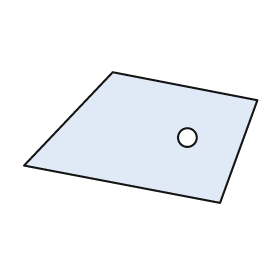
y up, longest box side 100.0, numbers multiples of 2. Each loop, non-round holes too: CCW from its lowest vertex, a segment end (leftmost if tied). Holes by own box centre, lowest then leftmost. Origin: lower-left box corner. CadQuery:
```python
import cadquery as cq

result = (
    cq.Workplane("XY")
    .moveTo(84.0, 0.0)
    .lineTo(100.0, 44.0)
    .lineTo(38.0, 56.0)
    .lineTo(0.0, 16.0)
    .close()
    .moveTo(70.0, 28.0)
    .circle(4.0)
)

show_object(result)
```